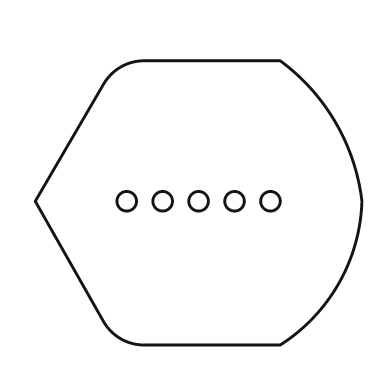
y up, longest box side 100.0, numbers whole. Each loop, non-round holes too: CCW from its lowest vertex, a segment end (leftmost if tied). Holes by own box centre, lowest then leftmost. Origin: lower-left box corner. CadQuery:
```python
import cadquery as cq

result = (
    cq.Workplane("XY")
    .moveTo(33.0, 0.0)
    .lineTo(75.0, 0.0)
    .threePointArc((93.0, 19.0), (100.0, 44.0))
    .threePointArc((92.0, 68.0), (75.0, 87.0))
    .lineTo(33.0, 87.0)
    .threePointArc((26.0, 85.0), (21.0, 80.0))
    .lineTo(0.0, 44.0)
    .lineTo(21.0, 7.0)
    .threePointArc((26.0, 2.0), (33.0, 0.0))
    .close()
    .moveTo(28.0, 44.0)
    .circle(3.0)
    .moveTo(39.0, 44.0)
    .circle(3.0)
    .moveTo(50.0, 44.0)
    .circle(3.0)
    .moveTo(61.0, 44.0)
    .circle(3.0)
    .moveTo(72.0, 44.0)
    .circle(3.0)
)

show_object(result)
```